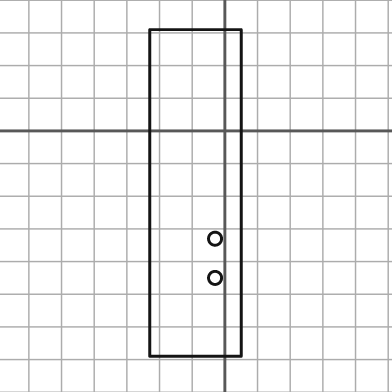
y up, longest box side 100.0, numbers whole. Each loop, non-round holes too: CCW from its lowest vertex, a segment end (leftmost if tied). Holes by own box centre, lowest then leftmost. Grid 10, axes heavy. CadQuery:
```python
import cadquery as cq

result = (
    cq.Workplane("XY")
    .moveTo(-23.0, -69.0)
    .lineTo(5.0, -69.0)
    .lineTo(5.0, 31.0)
    .lineTo(-23.0, 31.0)
    .close()
    .moveTo(-3.0, -45.0)
    .circle(2.0)
    .moveTo(-3.0, -33.0)
    .circle(2.0)
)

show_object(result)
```